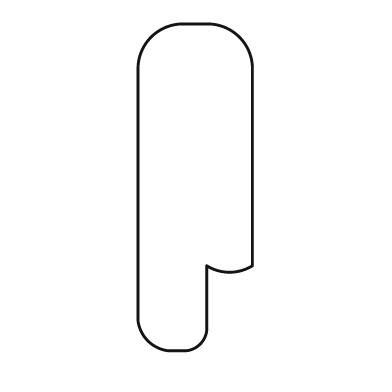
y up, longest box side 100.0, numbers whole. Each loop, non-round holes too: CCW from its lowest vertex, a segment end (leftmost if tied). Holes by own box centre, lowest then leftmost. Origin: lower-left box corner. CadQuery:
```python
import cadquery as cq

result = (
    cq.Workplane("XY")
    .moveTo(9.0, 0.0)
    .lineTo(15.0, 0.0)
    .threePointArc((19.0, 2.0), (21.0, 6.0))
    .lineTo(21.0, 26.0)
    .threePointArc((28.0, 24.0), (35.0, 26.0))
    .lineTo(35.0, 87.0)
    .threePointArc((31.0, 96.0), (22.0, 100.0))
    .lineTo(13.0, 100.0)
    .threePointArc((4.0, 96.0), (0.0, 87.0))
    .lineTo(0.0, 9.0)
    .threePointArc((3.0, 3.0), (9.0, 0.0))
    .close()
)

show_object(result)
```